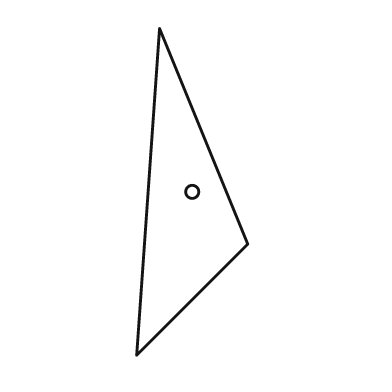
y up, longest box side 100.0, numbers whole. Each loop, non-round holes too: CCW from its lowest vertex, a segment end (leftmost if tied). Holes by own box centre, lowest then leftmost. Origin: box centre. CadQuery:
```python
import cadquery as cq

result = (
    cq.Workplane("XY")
    .moveTo(-17.0, -50.0)
    .lineTo(17.0, -16.0)
    .lineTo(-10.0, 50.0)
    .close()
    .moveTo(0.0, 0.0)
    .circle(2.0)
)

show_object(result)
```